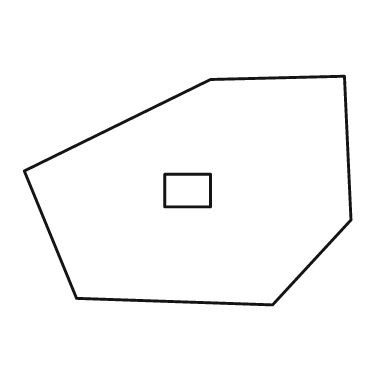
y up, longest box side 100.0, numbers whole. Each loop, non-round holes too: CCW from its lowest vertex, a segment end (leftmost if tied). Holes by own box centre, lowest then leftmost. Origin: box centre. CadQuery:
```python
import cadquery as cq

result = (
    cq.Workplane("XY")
    .moveTo(26.0, -35.0)
    .lineTo(50.0, -9.0)
    .lineTo(48.0, 35.0)
    .lineTo(7.0, 34.0)
    .lineTo(-50.0, 6.0)
    .lineTo(-34.0, -33.0)
    .close()
    .moveTo(-7.0, -5.0)
    .lineTo(7.0, -5.0)
    .lineTo(7.0, 5.0)
    .lineTo(-7.0, 5.0)
    .close()
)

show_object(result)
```